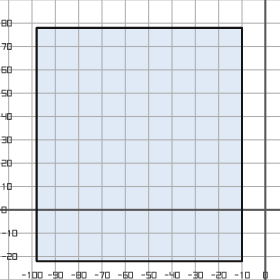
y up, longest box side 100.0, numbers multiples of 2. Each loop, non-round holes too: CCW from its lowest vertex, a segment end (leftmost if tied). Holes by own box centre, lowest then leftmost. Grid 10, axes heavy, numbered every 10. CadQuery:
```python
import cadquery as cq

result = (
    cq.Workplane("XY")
    .moveTo(-98.0, -22.0)
    .lineTo(-10.0, -22.0)
    .lineTo(-10.0, 78.0)
    .lineTo(-98.0, 78.0)
    .close()
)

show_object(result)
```